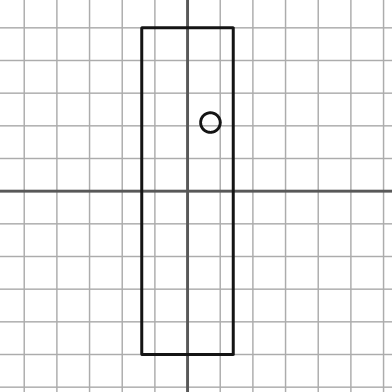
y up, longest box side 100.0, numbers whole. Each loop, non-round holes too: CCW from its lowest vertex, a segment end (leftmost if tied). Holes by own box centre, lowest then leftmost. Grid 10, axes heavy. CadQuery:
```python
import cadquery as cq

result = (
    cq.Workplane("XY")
    .moveTo(-14.0, -50.0)
    .lineTo(14.0, -50.0)
    .lineTo(14.0, 50.0)
    .lineTo(-14.0, 50.0)
    .close()
    .moveTo(7.0, 21.0)
    .circle(3.0)
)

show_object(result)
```